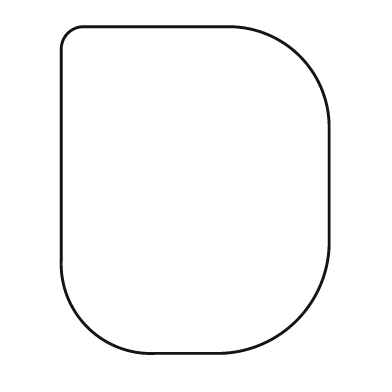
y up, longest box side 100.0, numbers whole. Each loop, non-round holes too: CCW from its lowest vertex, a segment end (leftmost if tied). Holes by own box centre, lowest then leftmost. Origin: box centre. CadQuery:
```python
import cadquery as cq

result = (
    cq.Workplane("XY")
    .moveTo(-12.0, -50.0)
    .lineTo(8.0, -50.0)
    .threePointArc((31.0, -40.0), (41.0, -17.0))
    .lineTo(41.0, 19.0)
    .threePointArc((32.0, 41.0), (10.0, 50.0))
    .lineTo(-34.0, 50.0)
    .threePointArc((-39.0, 48.0), (-41.0, 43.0))
    .lineTo(-41.0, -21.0)
    .threePointArc((-33.0, -42.0), (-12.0, -50.0))
    .close()
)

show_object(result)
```